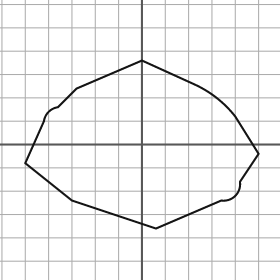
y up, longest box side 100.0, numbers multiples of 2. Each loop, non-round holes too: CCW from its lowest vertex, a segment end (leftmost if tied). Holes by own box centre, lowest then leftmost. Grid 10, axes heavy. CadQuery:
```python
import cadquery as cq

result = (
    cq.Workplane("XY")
    .moveTo(6.0, -36.0)
    .lineTo(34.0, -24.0)
    .threePointArc((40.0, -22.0), (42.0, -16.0))
    .lineTo(50.0, -4.0)
    .lineTo(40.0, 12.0)
    .threePointArc((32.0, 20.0), (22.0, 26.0))
    .lineTo(0.0, 36.0)
    .lineTo(-28.0, 24.0)
    .lineTo(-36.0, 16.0)
    .threePointArc((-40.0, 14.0), (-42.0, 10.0))
    .lineTo(-50.0, -8.0)
    .lineTo(-30.0, -24.0)
    .close()
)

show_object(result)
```